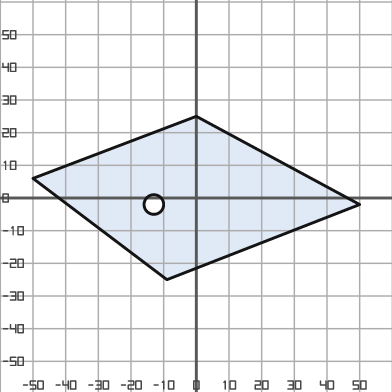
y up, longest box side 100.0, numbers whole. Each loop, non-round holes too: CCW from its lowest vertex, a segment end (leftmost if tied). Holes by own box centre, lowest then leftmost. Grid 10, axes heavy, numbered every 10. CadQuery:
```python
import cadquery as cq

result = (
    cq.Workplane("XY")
    .moveTo(-9.0, -25.0)
    .lineTo(50.0, -2.0)
    .lineTo(0.0, 25.0)
    .lineTo(-50.0, 6.0)
    .close()
    .moveTo(-13.0, -2.0)
    .circle(3.0)
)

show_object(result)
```